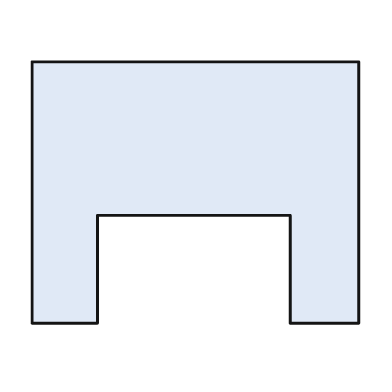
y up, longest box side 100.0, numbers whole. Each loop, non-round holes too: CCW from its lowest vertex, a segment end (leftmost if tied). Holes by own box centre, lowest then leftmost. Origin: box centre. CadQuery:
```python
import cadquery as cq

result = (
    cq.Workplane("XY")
    .moveTo(-50.0, -40.0)
    .lineTo(-30.0, -40.0)
    .lineTo(-30.0, -7.0)
    .lineTo(29.0, -7.0)
    .lineTo(29.0, -40.0)
    .lineTo(50.0, -40.0)
    .lineTo(50.0, 40.0)
    .lineTo(-50.0, 40.0)
    .close()
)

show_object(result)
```